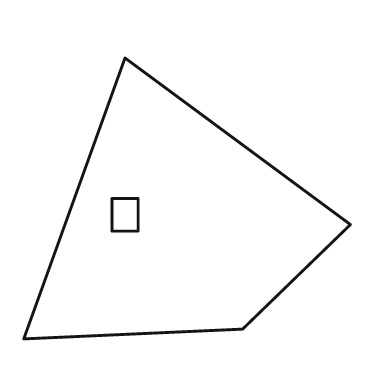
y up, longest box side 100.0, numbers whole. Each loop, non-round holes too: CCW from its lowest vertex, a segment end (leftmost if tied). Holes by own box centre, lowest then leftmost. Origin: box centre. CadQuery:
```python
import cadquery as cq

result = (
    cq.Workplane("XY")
    .moveTo(-50.0, -43.0)
    .lineTo(17.0, -40.0)
    .lineTo(50.0, -8.0)
    .lineTo(-19.0, 43.0)
    .close()
    .moveTo(-23.0, -10.0)
    .lineTo(-15.0, -10.0)
    .lineTo(-15.0, 0.0)
    .lineTo(-23.0, 0.0)
    .close()
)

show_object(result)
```